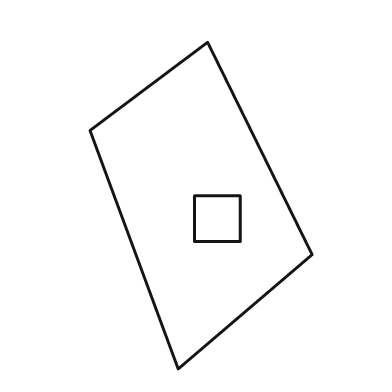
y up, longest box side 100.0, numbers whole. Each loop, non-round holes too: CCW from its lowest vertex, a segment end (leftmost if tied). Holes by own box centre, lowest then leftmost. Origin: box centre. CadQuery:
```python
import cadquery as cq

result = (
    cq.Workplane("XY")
    .moveTo(-7.0, -50.0)
    .lineTo(34.0, -15.0)
    .lineTo(2.0, 50.0)
    .lineTo(-34.0, 23.0)
    .close()
    .moveTo(-2.0, -11.0)
    .lineTo(12.0, -11.0)
    .lineTo(12.0, 3.0)
    .lineTo(-2.0, 3.0)
    .close()
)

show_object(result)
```